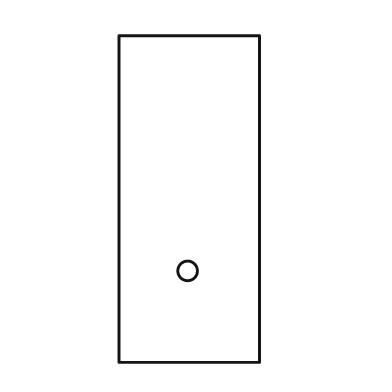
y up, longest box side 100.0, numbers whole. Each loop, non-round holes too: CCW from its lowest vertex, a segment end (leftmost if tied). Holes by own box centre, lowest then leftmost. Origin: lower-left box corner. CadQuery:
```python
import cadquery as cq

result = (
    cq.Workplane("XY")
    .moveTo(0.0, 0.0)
    .lineTo(43.0, 0.0)
    .lineTo(43.0, 100.0)
    .lineTo(0.0, 100.0)
    .close()
    .moveTo(21.0, 28.0)
    .circle(3.0)
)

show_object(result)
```